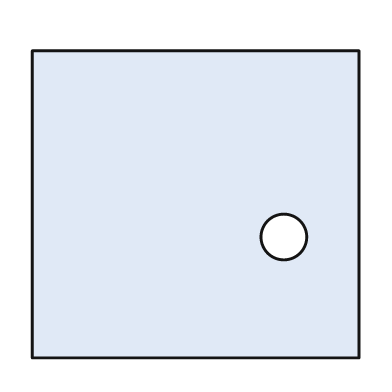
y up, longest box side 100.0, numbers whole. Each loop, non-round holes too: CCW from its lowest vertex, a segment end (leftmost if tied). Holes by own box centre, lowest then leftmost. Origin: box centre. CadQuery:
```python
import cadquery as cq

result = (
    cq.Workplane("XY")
    .moveTo(-50.0, -47.0)
    .lineTo(50.0, -47.0)
    .lineTo(50.0, 47.0)
    .lineTo(-50.0, 47.0)
    .close()
    .moveTo(27.0, -10.0)
    .circle(7.0)
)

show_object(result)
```